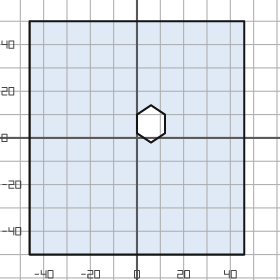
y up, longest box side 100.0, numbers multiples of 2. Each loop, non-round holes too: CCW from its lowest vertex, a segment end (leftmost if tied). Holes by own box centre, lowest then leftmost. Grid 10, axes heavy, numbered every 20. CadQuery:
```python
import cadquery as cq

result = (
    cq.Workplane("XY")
    .moveTo(-46.0, -50.0)
    .lineTo(46.0, -50.0)
    .lineTo(46.0, 50.0)
    .lineTo(-46.0, 50.0)
    .close()
    .moveTo(6.0, -2.0)
    .lineTo(12.0, 2.0)
    .lineTo(12.0, 10.0)
    .lineTo(6.0, 14.0)
    .lineTo(0.0, 10.0)
    .lineTo(0.0, 2.0)
    .close()
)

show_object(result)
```